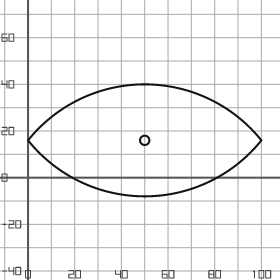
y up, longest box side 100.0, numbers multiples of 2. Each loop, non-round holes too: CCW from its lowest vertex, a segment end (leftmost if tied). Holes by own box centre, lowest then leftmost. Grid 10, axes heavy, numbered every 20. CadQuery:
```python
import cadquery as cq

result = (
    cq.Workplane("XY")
    .moveTo(0.0, 16.0)
    .threePointArc((50.0, -8.0), (100.0, 16.0))
    .threePointArc((50.0, 40.0), (0.0, 16.0))
    .close()
    .moveTo(50.0, 16.0)
    .circle(2.0)
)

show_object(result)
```